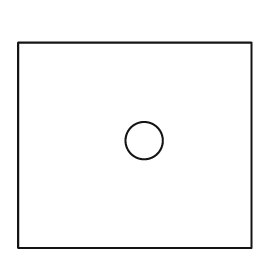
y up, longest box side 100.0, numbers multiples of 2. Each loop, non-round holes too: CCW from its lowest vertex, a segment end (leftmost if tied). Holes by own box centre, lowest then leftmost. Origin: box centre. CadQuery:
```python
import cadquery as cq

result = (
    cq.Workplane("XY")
    .moveTo(-50.0, -44.0)
    .lineTo(50.0, -44.0)
    .lineTo(50.0, 44.0)
    .lineTo(-50.0, 44.0)
    .close()
    .moveTo(4.0, 2.0)
    .circle(8.0)
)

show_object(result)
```